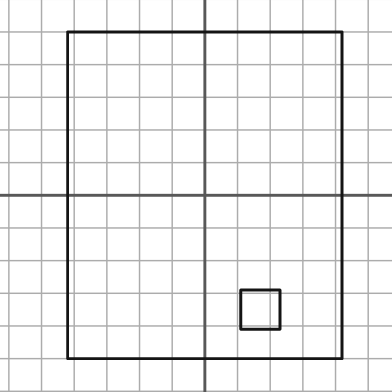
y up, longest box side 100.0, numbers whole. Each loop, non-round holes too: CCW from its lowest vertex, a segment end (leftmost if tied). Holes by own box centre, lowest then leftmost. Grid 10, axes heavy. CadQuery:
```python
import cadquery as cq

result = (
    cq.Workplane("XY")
    .moveTo(-42.0, -50.0)
    .lineTo(42.0, -50.0)
    .lineTo(42.0, 50.0)
    .lineTo(-42.0, 50.0)
    .close()
    .moveTo(11.0, -41.0)
    .lineTo(23.0, -41.0)
    .lineTo(23.0, -29.0)
    .lineTo(11.0, -29.0)
    .close()
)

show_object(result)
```